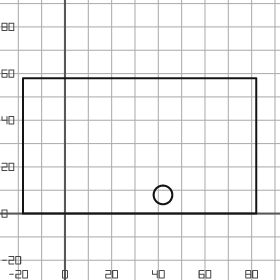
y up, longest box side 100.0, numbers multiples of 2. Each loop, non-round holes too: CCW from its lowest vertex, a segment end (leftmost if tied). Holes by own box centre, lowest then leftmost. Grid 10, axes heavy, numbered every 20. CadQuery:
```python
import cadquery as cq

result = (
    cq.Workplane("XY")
    .moveTo(-18.0, 0.0)
    .lineTo(82.0, 0.0)
    .lineTo(82.0, 58.0)
    .lineTo(-18.0, 58.0)
    .close()
    .moveTo(42.0, 8.0)
    .circle(4.0)
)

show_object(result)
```